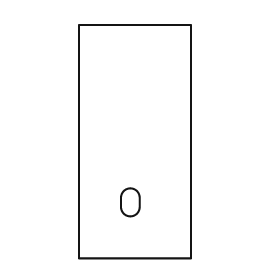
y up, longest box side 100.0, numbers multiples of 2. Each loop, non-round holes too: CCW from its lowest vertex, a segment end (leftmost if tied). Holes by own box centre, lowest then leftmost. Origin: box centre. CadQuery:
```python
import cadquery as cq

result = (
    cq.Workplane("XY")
    .moveTo(-24.0, -50.0)
    .lineTo(24.0, -50.0)
    .lineTo(24.0, 50.0)
    .lineTo(-24.0, 50.0)
    .close()
    .moveTo(-6.0, -28.0)
    .threePointArc((-2.0, -32.0), (2.0, -28.0))
    .lineTo(2.0, -24.0)
    .threePointArc((-2.0, -20.0), (-6.0, -24.0))
    .close()
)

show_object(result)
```